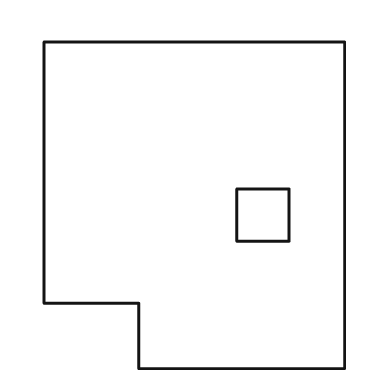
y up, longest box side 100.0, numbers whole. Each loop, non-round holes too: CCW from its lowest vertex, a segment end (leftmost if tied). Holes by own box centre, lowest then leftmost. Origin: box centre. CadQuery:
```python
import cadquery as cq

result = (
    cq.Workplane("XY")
    .moveTo(-17.0, -50.0)
    .lineTo(46.0, -50.0)
    .lineTo(46.0, 50.0)
    .lineTo(-46.0, 50.0)
    .lineTo(-46.0, -30.0)
    .lineTo(-17.0, -30.0)
    .close()
    .moveTo(13.0, -11.0)
    .lineTo(29.0, -11.0)
    .lineTo(29.0, 5.0)
    .lineTo(13.0, 5.0)
    .close()
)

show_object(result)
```